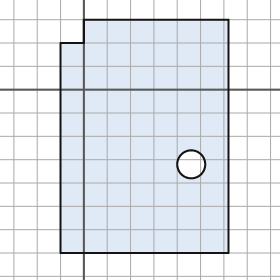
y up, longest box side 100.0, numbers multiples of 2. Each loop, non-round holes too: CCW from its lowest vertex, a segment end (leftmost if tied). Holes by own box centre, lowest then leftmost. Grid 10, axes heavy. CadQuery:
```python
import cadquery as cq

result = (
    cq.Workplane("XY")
    .moveTo(-10.0, -70.0)
    .lineTo(62.0, -70.0)
    .lineTo(62.0, 30.0)
    .lineTo(0.0, 30.0)
    .lineTo(0.0, 20.0)
    .lineTo(-10.0, 20.0)
    .close()
    .moveTo(46.0, -32.0)
    .circle(6.0)
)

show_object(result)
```